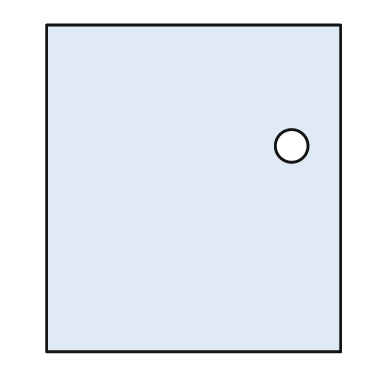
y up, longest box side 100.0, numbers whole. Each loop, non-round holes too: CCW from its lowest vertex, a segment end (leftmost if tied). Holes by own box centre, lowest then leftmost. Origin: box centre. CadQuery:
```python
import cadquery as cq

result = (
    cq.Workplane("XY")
    .moveTo(-45.0, -50.0)
    .lineTo(45.0, -50.0)
    .lineTo(45.0, 50.0)
    .lineTo(-45.0, 50.0)
    .close()
    .moveTo(30.0, 13.0)
    .circle(5.0)
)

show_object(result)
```